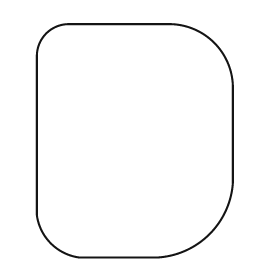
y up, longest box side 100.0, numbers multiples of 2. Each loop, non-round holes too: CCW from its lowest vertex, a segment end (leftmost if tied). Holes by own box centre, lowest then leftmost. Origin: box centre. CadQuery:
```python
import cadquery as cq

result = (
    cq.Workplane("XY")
    .moveTo(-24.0, -50.0)
    .lineTo(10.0, -50.0)
    .threePointArc((32.0, -40.0), (42.0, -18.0))
    .lineTo(42.0, 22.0)
    .threePointArc((34.0, 42.0), (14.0, 50.0))
    .lineTo(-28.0, 50.0)
    .threePointArc((-38.0, 46.0), (-42.0, 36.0))
    .lineTo(-42.0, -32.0)
    .threePointArc((-36.0, -44.0), (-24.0, -50.0))
    .close()
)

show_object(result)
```